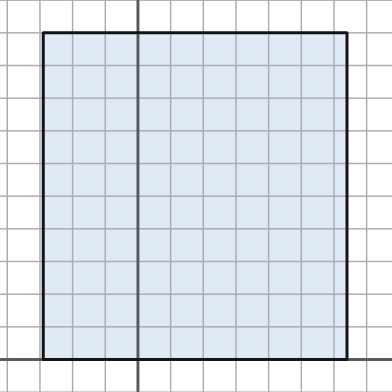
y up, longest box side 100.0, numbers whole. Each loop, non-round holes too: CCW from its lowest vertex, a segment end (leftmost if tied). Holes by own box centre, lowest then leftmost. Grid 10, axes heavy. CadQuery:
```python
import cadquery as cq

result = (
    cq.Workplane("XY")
    .moveTo(-29.0, 0.0)
    .lineTo(64.0, 0.0)
    .lineTo(64.0, 100.0)
    .lineTo(-29.0, 100.0)
    .close()
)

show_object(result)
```